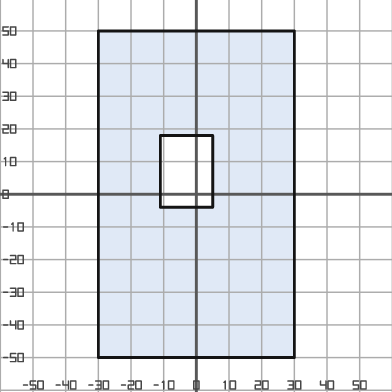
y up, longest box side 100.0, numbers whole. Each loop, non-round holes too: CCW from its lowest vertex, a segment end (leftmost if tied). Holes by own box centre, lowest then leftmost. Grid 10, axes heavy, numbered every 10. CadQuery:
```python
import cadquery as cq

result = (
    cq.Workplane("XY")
    .moveTo(-30.0, -50.0)
    .lineTo(30.0, -50.0)
    .lineTo(30.0, 50.0)
    .lineTo(-30.0, 50.0)
    .close()
    .moveTo(-11.0, -4.0)
    .lineTo(5.0, -4.0)
    .lineTo(5.0, 18.0)
    .lineTo(-11.0, 18.0)
    .close()
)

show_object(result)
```